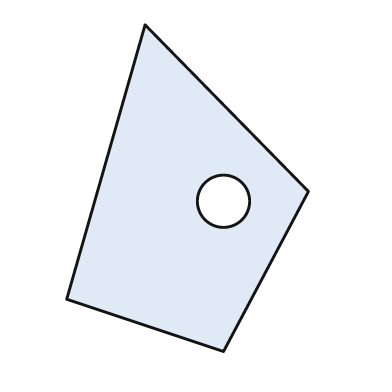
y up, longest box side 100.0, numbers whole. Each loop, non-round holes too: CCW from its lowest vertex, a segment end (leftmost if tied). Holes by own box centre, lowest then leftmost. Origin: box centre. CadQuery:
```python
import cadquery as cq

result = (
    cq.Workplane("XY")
    .moveTo(11.0, -50.0)
    .lineTo(37.0, -1.0)
    .lineTo(-13.0, 50.0)
    .lineTo(-37.0, -34.0)
    .close()
    .moveTo(11.0, -4.0)
    .circle(8.0)
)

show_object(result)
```